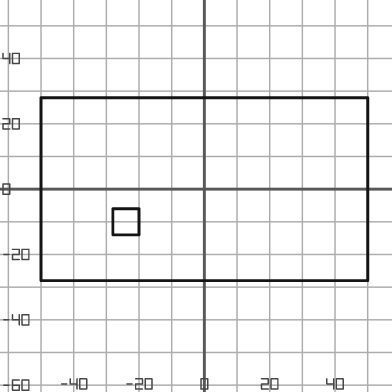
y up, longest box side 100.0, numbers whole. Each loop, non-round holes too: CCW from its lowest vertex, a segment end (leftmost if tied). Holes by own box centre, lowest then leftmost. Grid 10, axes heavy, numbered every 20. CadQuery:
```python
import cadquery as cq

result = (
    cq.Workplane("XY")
    .moveTo(-50.0, -28.0)
    .lineTo(50.0, -28.0)
    .lineTo(50.0, 28.0)
    .lineTo(-50.0, 28.0)
    .close()
    .moveTo(-28.0, -14.0)
    .lineTo(-20.0, -14.0)
    .lineTo(-20.0, -6.0)
    .lineTo(-28.0, -6.0)
    .close()
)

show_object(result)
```